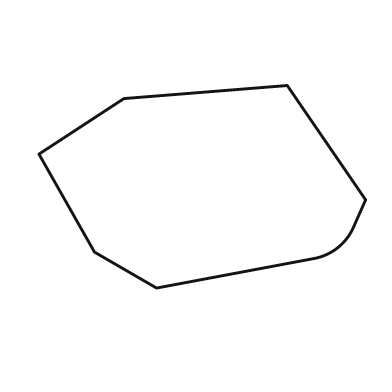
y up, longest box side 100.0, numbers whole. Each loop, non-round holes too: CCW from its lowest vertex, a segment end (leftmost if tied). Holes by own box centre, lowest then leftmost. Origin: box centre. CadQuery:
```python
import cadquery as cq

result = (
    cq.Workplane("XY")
    .moveTo(-14.0, -31.0)
    .lineTo(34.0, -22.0)
    .threePointArc((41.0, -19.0), (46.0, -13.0))
    .lineTo(50.0, -4.0)
    .lineTo(26.0, 31.0)
    .lineTo(-24.0, 27.0)
    .lineTo(-50.0, 10.0)
    .lineTo(-33.0, -20.0)
    .close()
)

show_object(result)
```